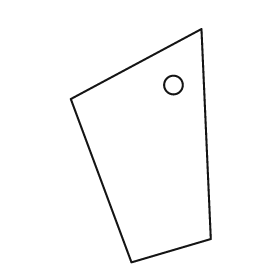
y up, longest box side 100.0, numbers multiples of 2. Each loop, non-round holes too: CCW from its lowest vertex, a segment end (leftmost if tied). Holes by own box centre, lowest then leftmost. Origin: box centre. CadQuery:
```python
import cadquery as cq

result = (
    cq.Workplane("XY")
    .moveTo(-4.0, -50.0)
    .lineTo(30.0, -40.0)
    .lineTo(26.0, 50.0)
    .lineTo(-30.0, 20.0)
    .close()
    .moveTo(14.0, 26.0)
    .circle(4.0)
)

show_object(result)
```